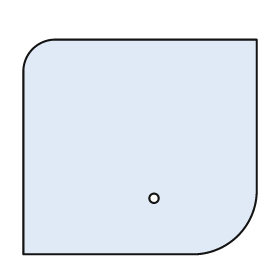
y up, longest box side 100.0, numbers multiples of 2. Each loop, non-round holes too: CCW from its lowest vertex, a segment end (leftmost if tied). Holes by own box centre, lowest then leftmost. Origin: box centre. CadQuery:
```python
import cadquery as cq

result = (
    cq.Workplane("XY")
    .moveTo(-50.0, -46.0)
    .lineTo(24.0, -46.0)
    .threePointArc((42.0, -38.0), (50.0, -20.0))
    .lineTo(50.0, 46.0)
    .lineTo(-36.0, 46.0)
    .threePointArc((-46.0, 42.0), (-50.0, 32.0))
    .close()
    .moveTo(6.0, -22.0)
    .circle(2.0)
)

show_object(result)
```